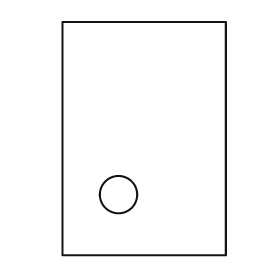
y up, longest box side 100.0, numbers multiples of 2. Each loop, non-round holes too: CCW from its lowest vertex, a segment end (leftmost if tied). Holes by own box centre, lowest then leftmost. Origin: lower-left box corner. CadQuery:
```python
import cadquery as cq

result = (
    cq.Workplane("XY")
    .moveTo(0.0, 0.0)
    .lineTo(70.0, 0.0)
    .lineTo(70.0, 100.0)
    .lineTo(0.0, 100.0)
    .close()
    .moveTo(24.0, 26.0)
    .circle(8.0)
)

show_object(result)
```